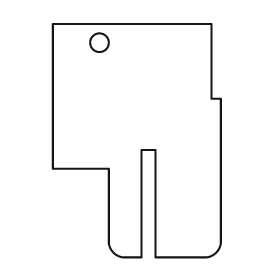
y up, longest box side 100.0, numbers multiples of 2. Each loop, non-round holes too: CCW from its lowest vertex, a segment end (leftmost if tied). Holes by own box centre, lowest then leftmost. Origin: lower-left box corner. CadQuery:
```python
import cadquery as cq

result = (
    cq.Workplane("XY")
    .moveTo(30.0, 0.0)
    .lineTo(38.0, 0.0)
    .lineTo(38.0, 46.0)
    .lineTo(44.0, 46.0)
    .lineTo(44.0, 0.0)
    .lineTo(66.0, 0.0)
    .threePointArc((70.0, 2.0), (72.0, 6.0))
    .lineTo(72.0, 68.0)
    .lineTo(68.0, 68.0)
    .lineTo(68.0, 100.0)
    .lineTo(0.0, 100.0)
    .lineTo(0.0, 38.0)
    .lineTo(24.0, 38.0)
    .lineTo(24.0, 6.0)
    .threePointArc((26.0, 2.0), (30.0, 0.0))
    .close()
    .moveTo(20.0, 92.0)
    .circle(4.0)
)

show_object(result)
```